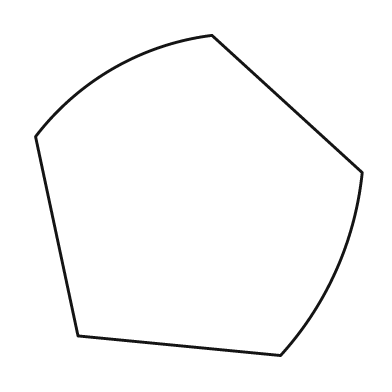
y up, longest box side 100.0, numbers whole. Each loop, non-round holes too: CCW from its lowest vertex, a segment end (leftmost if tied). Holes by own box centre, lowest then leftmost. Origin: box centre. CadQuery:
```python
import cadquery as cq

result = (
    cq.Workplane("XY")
    .moveTo(25.0, -49.0)
    .threePointArc((42.0, -23.0), (50.0, 7.0))
    .lineTo(4.0, 49.0)
    .threePointArc((-26.0, 39.0), (-50.0, 18.0))
    .lineTo(-37.0, -43.0)
    .close()
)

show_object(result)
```